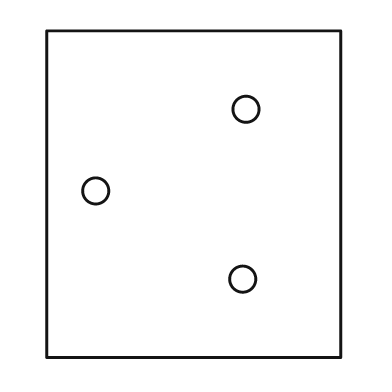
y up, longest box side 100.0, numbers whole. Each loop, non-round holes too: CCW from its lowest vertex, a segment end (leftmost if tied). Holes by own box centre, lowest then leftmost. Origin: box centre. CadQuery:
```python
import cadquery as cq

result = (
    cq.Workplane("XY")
    .moveTo(-45.0, -50.0)
    .lineTo(45.0, -50.0)
    .lineTo(45.0, 50.0)
    .lineTo(-45.0, 50.0)
    .close()
    .moveTo(15.0, -26.0)
    .circle(4.0)
    .moveTo(-30.0, 1.0)
    .circle(4.0)
    .moveTo(16.0, 26.0)
    .circle(4.0)
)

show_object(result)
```